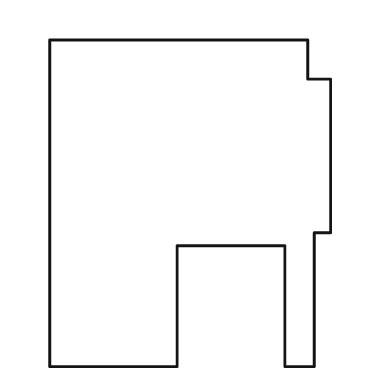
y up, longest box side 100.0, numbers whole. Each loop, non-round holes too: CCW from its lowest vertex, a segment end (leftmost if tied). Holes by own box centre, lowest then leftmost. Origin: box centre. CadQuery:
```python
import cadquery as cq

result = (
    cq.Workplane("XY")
    .moveTo(-43.0, -50.0)
    .lineTo(-4.0, -50.0)
    .lineTo(-4.0, -13.0)
    .lineTo(29.0, -13.0)
    .lineTo(29.0, -50.0)
    .lineTo(38.0, -50.0)
    .lineTo(38.0, -9.0)
    .lineTo(43.0, -9.0)
    .lineTo(43.0, 38.0)
    .lineTo(36.0, 38.0)
    .lineTo(36.0, 50.0)
    .lineTo(-43.0, 50.0)
    .close()
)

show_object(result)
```